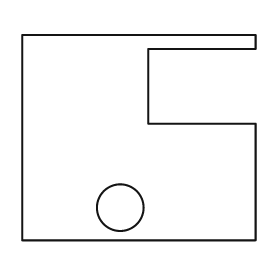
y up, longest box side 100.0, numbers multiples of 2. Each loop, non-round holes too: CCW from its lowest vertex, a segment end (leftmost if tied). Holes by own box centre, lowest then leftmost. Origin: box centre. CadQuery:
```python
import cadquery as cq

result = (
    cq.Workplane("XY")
    .moveTo(-50.0, -44.0)
    .lineTo(50.0, -44.0)
    .lineTo(50.0, 6.0)
    .lineTo(4.0, 6.0)
    .lineTo(4.0, 38.0)
    .lineTo(50.0, 38.0)
    .lineTo(50.0, 44.0)
    .lineTo(-50.0, 44.0)
    .close()
    .moveTo(-8.0, -30.0)
    .circle(10.0)
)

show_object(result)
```